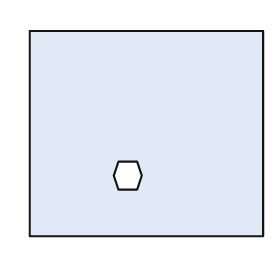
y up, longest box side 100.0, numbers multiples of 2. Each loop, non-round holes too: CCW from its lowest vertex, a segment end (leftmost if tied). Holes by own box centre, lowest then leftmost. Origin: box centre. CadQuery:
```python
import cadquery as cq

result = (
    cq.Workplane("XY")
    .moveTo(-50.0, -44.0)
    .lineTo(50.0, -44.0)
    .lineTo(50.0, 44.0)
    .lineTo(-50.0, 44.0)
    .close()
    .moveTo(-12.0, -24.0)
    .lineTo(-4.0, -24.0)
    .lineTo(-2.0, -18.0)
    .lineTo(-4.0, -12.0)
    .lineTo(-12.0, -12.0)
    .lineTo(-14.0, -18.0)
    .close()
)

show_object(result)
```